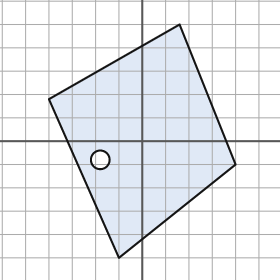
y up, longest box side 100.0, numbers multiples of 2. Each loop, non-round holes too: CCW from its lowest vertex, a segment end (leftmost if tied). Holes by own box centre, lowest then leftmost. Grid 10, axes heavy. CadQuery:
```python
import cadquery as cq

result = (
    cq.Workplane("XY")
    .moveTo(-10.0, -50.0)
    .lineTo(40.0, -10.0)
    .lineTo(16.0, 50.0)
    .lineTo(-40.0, 18.0)
    .close()
    .moveTo(-18.0, -8.0)
    .circle(4.0)
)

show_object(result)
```